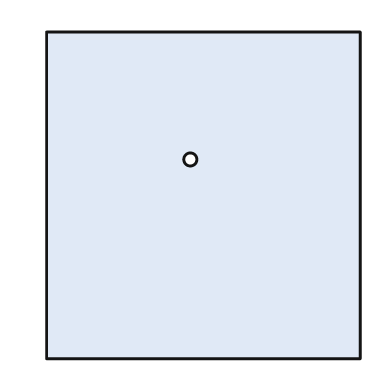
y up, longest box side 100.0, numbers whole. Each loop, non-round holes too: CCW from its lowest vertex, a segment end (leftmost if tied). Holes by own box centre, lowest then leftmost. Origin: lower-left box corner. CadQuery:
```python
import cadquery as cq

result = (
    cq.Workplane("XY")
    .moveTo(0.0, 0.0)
    .lineTo(96.0, 0.0)
    .lineTo(96.0, 100.0)
    .lineTo(0.0, 100.0)
    .close()
    .moveTo(44.0, 61.0)
    .circle(2.0)
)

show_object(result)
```